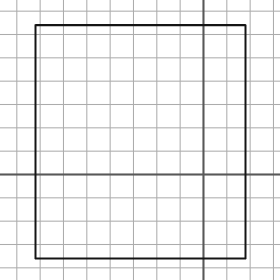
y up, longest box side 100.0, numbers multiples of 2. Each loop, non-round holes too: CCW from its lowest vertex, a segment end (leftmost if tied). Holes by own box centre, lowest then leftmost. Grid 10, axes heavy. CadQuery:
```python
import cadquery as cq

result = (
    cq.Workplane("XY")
    .moveTo(-72.0, -36.0)
    .lineTo(18.0, -36.0)
    .lineTo(18.0, 64.0)
    .lineTo(-72.0, 64.0)
    .close()
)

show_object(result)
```